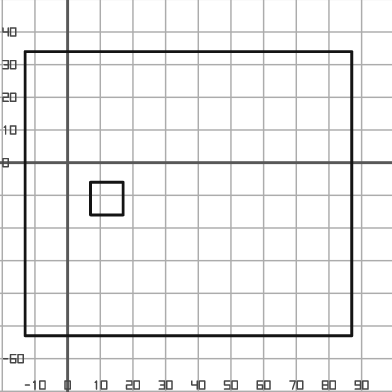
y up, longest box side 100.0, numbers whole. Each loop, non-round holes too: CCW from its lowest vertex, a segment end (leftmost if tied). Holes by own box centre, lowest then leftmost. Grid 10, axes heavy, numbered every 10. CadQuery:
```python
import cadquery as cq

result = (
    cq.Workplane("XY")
    .moveTo(-13.0, -53.0)
    .lineTo(87.0, -53.0)
    .lineTo(87.0, 34.0)
    .lineTo(-13.0, 34.0)
    .close()
    .moveTo(7.0, -16.0)
    .lineTo(17.0, -16.0)
    .lineTo(17.0, -6.0)
    .lineTo(7.0, -6.0)
    .close()
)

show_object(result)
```